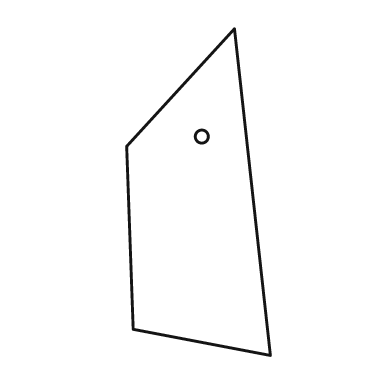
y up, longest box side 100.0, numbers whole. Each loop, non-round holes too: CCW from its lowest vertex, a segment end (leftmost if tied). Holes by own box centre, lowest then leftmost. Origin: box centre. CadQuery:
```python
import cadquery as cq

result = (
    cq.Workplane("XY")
    .moveTo(22.0, -50.0)
    .lineTo(11.0, 50.0)
    .lineTo(-22.0, 14.0)
    .lineTo(-20.0, -42.0)
    .close()
    .moveTo(1.0, 17.0)
    .circle(2.0)
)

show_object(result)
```